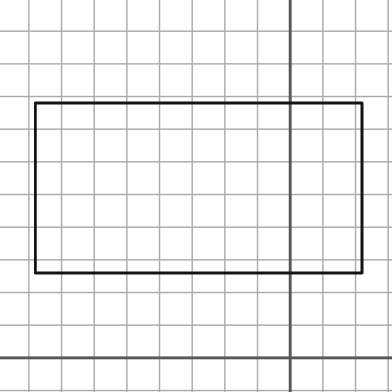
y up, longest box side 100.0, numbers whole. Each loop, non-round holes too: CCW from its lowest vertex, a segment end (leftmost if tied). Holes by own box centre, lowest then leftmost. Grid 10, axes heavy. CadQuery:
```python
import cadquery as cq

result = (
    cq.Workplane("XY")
    .moveTo(-78.0, 26.0)
    .lineTo(22.0, 26.0)
    .lineTo(22.0, 78.0)
    .lineTo(-78.0, 78.0)
    .close()
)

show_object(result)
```